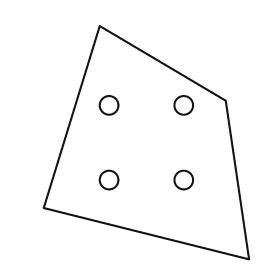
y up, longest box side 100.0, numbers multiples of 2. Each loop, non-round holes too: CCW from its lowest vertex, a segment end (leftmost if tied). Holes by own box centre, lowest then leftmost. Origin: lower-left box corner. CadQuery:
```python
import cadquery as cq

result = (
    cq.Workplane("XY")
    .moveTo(88.0, 0.0)
    .lineTo(78.0, 68.0)
    .lineTo(24.0, 100.0)
    .lineTo(0.0, 22.0)
    .close()
    .moveTo(28.0, 34.0)
    .circle(4.0)
    .moveTo(60.0, 34.0)
    .circle(4.0)
    .moveTo(28.0, 66.0)
    .circle(4.0)
    .moveTo(60.0, 66.0)
    .circle(4.0)
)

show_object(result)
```